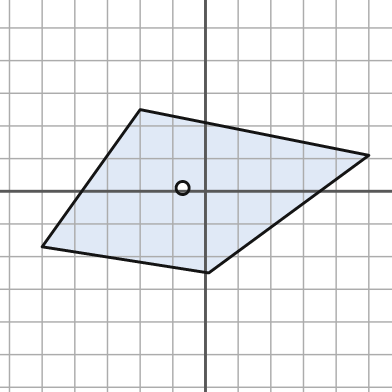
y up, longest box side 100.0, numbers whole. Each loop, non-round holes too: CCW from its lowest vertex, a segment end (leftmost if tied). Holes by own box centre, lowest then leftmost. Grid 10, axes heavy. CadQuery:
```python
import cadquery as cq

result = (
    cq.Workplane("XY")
    .moveTo(1.0, -25.0)
    .lineTo(50.0, 11.0)
    .lineTo(-20.0, 25.0)
    .lineTo(-50.0, -17.0)
    .close()
    .moveTo(-7.0, 1.0)
    .circle(2.0)
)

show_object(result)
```